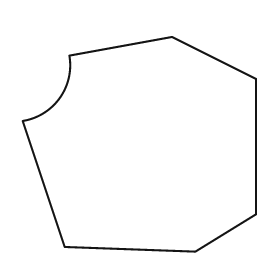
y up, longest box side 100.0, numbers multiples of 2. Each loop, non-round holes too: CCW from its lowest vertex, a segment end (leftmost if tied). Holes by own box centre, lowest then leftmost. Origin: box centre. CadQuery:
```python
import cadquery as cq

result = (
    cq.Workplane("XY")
    .moveTo(24.0, -46.0)
    .lineTo(50.0, -30.0)
    .lineTo(50.0, 28.0)
    .lineTo(14.0, 46.0)
    .lineTo(-30.0, 38.0)
    .threePointArc((-34.0, 20.0), (-50.0, 10.0))
    .lineTo(-32.0, -44.0)
    .close()
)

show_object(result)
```